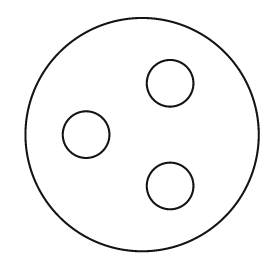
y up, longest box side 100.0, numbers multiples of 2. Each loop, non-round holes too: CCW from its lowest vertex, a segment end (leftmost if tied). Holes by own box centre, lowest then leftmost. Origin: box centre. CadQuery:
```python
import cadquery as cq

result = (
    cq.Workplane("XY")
    .moveTo(0.0, 0.0)
    .circle(50.0)
    .moveTo(12.0, -22.0)
    .circle(10.0)
    .moveTo(-24.0, 0.0)
    .circle(10.0)
    .moveTo(12.0, 22.0)
    .circle(10.0)
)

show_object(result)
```